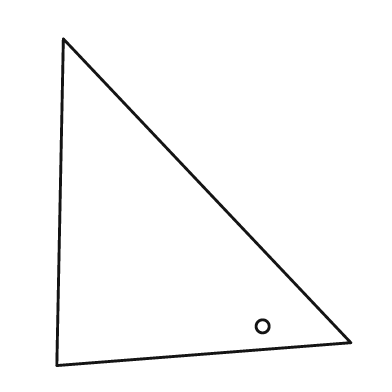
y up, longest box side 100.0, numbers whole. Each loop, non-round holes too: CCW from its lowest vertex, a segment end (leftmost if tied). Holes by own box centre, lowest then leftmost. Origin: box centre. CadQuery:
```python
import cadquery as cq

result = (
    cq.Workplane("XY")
    .moveTo(-45.0, -50.0)
    .lineTo(45.0, -43.0)
    .lineTo(-43.0, 50.0)
    .close()
    .moveTo(18.0, -38.0)
    .circle(2.0)
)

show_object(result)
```